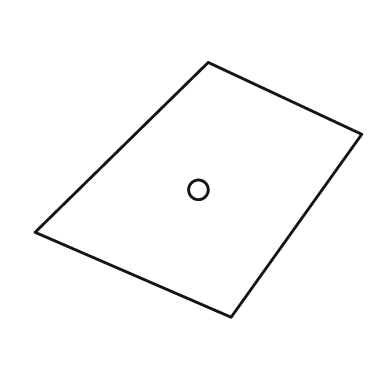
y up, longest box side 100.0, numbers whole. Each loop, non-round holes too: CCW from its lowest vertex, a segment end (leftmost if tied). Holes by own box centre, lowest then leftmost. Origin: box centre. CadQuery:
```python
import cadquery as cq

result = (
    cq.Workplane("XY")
    .moveTo(10.0, -39.0)
    .lineTo(50.0, 17.0)
    .lineTo(3.0, 39.0)
    .lineTo(-50.0, -13.0)
    .close()
    .moveTo(0.0, 0.0)
    .circle(3.0)
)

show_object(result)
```